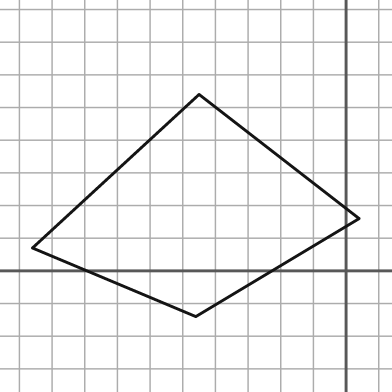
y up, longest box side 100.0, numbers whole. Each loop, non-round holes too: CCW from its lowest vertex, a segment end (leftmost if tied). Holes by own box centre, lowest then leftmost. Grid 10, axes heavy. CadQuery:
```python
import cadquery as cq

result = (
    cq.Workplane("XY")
    .moveTo(-46.0, -14.0)
    .lineTo(4.0, 16.0)
    .lineTo(-45.0, 54.0)
    .lineTo(-96.0, 7.0)
    .close()
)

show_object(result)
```